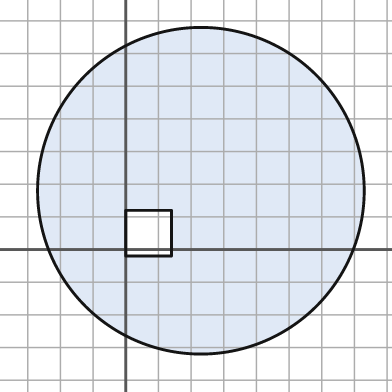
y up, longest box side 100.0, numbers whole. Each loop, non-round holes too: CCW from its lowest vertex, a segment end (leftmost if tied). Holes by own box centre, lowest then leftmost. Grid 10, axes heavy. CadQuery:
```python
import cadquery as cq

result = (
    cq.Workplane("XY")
    .moveTo(23.0, 18.0)
    .circle(50.0)
    .moveTo(0.0, -2.0)
    .lineTo(14.0, -2.0)
    .lineTo(14.0, 12.0)
    .lineTo(0.0, 12.0)
    .close()
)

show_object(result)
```